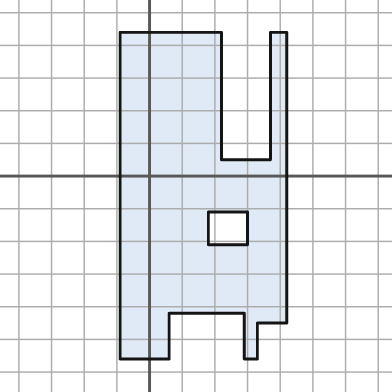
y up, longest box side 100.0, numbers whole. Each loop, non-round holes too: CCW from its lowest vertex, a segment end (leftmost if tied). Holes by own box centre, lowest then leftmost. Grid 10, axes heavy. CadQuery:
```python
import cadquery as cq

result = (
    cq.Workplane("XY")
    .moveTo(-9.0, -56.0)
    .lineTo(6.0, -56.0)
    .lineTo(6.0, -42.0)
    .lineTo(29.0, -42.0)
    .lineTo(29.0, -56.0)
    .lineTo(33.0, -56.0)
    .lineTo(33.0, -45.0)
    .lineTo(42.0, -45.0)
    .lineTo(42.0, 44.0)
    .lineTo(37.0, 44.0)
    .lineTo(37.0, 5.0)
    .lineTo(22.0, 5.0)
    .lineTo(22.0, 44.0)
    .lineTo(-9.0, 44.0)
    .close()
    .moveTo(18.0, -21.0)
    .lineTo(30.0, -21.0)
    .lineTo(30.0, -11.0)
    .lineTo(18.0, -11.0)
    .close()
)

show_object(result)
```